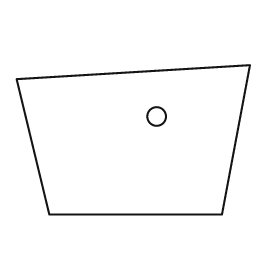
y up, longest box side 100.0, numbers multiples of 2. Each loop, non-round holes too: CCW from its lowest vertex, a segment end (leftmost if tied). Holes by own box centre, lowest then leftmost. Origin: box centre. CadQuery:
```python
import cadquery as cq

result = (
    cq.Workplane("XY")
    .moveTo(-36.0, -32.0)
    .lineTo(38.0, -32.0)
    .lineTo(50.0, 32.0)
    .lineTo(-50.0, 26.0)
    .close()
    .moveTo(10.0, 10.0)
    .circle(4.0)
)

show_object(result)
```